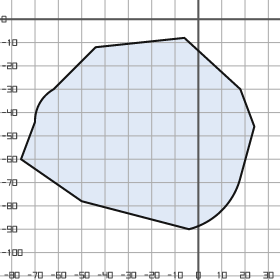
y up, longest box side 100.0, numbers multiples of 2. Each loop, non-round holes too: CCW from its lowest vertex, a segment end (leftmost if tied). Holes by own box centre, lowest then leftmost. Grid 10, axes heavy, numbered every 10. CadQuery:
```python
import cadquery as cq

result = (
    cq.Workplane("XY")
    .moveTo(-4.0, -90.0)
    .threePointArc((10.0, -82.0), (18.0, -68.0))
    .lineTo(24.0, -46.0)
    .lineTo(18.0, -30.0)
    .lineTo(-6.0, -8.0)
    .lineTo(-44.0, -12.0)
    .lineTo(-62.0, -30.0)
    .threePointArc((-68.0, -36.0), (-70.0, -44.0))
    .lineTo(-76.0, -60.0)
    .lineTo(-50.0, -78.0)
    .close()
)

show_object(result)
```